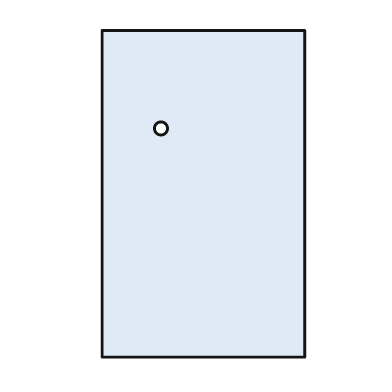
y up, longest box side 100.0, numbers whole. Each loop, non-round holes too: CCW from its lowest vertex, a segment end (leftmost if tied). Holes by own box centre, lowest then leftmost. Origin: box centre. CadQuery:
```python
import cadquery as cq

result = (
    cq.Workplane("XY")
    .moveTo(-31.0, -50.0)
    .lineTo(31.0, -50.0)
    .lineTo(31.0, 50.0)
    .lineTo(-31.0, 50.0)
    .close()
    .moveTo(-13.0, 20.0)
    .circle(2.0)
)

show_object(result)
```